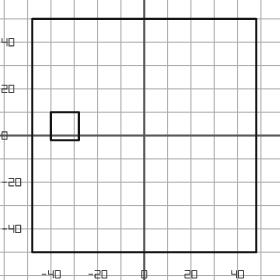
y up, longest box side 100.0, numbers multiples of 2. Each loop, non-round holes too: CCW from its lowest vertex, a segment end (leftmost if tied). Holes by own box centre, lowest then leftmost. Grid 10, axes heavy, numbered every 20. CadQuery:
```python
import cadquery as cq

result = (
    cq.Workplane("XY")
    .moveTo(-48.0, -50.0)
    .lineTo(48.0, -50.0)
    .lineTo(48.0, 50.0)
    .lineTo(-48.0, 50.0)
    .close()
    .moveTo(-40.0, -2.0)
    .lineTo(-28.0, -2.0)
    .lineTo(-28.0, 10.0)
    .lineTo(-40.0, 10.0)
    .close()
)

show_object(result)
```